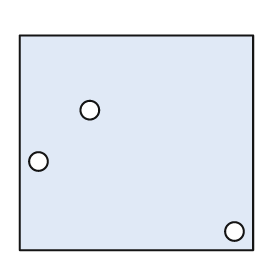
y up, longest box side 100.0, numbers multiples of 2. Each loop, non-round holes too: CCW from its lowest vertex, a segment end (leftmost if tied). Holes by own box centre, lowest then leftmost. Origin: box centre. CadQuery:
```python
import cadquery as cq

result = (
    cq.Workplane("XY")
    .moveTo(-50.0, -46.0)
    .lineTo(50.0, -46.0)
    .lineTo(50.0, 46.0)
    .lineTo(-50.0, 46.0)
    .close()
    .moveTo(42.0, -38.0)
    .circle(4.0)
    .moveTo(-42.0, -8.0)
    .circle(4.0)
    .moveTo(-20.0, 14.0)
    .circle(4.0)
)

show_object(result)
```